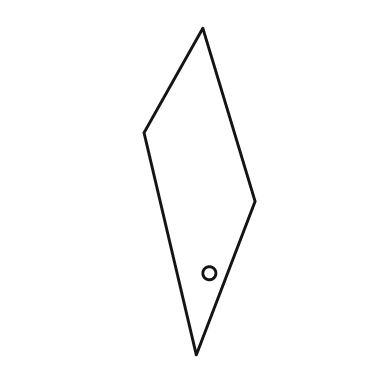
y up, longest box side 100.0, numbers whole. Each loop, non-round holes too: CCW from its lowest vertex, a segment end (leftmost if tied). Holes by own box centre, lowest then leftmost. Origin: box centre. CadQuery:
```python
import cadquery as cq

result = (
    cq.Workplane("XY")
    .moveTo(-1.0, -50.0)
    .lineTo(17.0, -3.0)
    .lineTo(1.0, 50.0)
    .lineTo(-17.0, 18.0)
    .close()
    .moveTo(3.0, -25.0)
    .circle(2.0)
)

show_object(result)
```